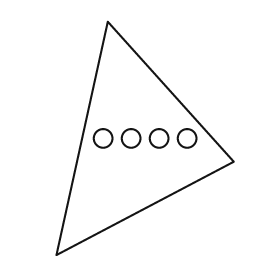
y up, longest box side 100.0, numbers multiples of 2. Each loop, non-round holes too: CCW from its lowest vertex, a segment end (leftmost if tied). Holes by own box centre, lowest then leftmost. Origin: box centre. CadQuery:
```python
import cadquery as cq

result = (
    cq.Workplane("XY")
    .moveTo(-38.0, -50.0)
    .lineTo(38.0, -10.0)
    .lineTo(-16.0, 50.0)
    .close()
    .moveTo(-18.0, 0.0)
    .circle(4.0)
    .moveTo(-6.0, 0.0)
    .circle(4.0)
    .moveTo(6.0, 0.0)
    .circle(4.0)
    .moveTo(18.0, 0.0)
    .circle(4.0)
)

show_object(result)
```